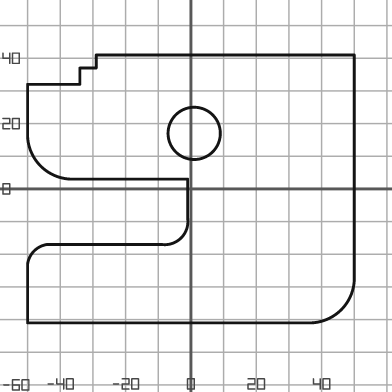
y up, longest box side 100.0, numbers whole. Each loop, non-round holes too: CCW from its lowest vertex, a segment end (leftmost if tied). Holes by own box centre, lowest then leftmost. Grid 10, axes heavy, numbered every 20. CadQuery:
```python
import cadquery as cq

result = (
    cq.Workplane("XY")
    .moveTo(-50.0, -41.0)
    .lineTo(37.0, -41.0)
    .threePointArc((46.0, -37.0), (50.0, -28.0))
    .lineTo(50.0, 41.0)
    .lineTo(-29.0, 41.0)
    .lineTo(-29.0, 37.0)
    .lineTo(-34.0, 37.0)
    .lineTo(-34.0, 32.0)
    .lineTo(-50.0, 32.0)
    .lineTo(-50.0, 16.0)
    .threePointArc((-46.0, 7.0), (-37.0, 3.0))
    .lineTo(-1.0, 3.0)
    .lineTo(-1.0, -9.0)
    .threePointArc((-3.0, -15.0), (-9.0, -17.0))
    .lineTo(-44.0, -17.0)
    .threePointArc((-48.0, -19.0), (-50.0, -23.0))
    .close()
    .moveTo(1.0, 17.0)
    .circle(8.0)
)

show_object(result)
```